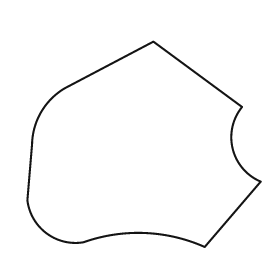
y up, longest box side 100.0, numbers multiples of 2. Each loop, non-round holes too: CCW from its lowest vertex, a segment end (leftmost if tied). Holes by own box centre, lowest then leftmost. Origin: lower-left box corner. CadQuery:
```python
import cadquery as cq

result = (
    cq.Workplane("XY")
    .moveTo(76.0, 0.0)
    .lineTo(100.0, 28.0)
    .threePointArc((88.0, 42.0), (92.0, 60.0))
    .lineTo(54.0, 88.0)
    .lineTo(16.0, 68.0)
    .threePointArc((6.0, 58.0), (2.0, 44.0))
    .lineTo(0.0, 20.0)
    .threePointArc((8.0, 6.0), (24.0, 2.0))
    .threePointArc((50.0, 6.0), (76.0, 0.0))
    .close()
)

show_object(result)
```